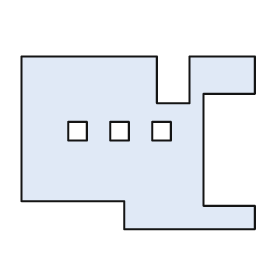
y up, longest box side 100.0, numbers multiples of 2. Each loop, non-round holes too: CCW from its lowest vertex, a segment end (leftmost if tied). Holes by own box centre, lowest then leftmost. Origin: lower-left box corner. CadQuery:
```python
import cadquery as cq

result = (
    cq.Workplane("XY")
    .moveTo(44.0, 0.0)
    .lineTo(100.0, 0.0)
    .lineTo(100.0, 10.0)
    .lineTo(78.0, 10.0)
    .lineTo(78.0, 58.0)
    .lineTo(100.0, 58.0)
    .lineTo(100.0, 74.0)
    .lineTo(72.0, 74.0)
    .lineTo(72.0, 54.0)
    .lineTo(58.0, 54.0)
    .lineTo(58.0, 74.0)
    .lineTo(0.0, 74.0)
    .lineTo(0.0, 12.0)
    .lineTo(44.0, 12.0)
    .close()
    .moveTo(20.0, 38.0)
    .lineTo(28.0, 38.0)
    .lineTo(28.0, 46.0)
    .lineTo(20.0, 46.0)
    .close()
    .moveTo(38.0, 38.0)
    .lineTo(46.0, 38.0)
    .lineTo(46.0, 46.0)
    .lineTo(38.0, 46.0)
    .close()
    .moveTo(56.0, 38.0)
    .lineTo(64.0, 38.0)
    .lineTo(64.0, 46.0)
    .lineTo(56.0, 46.0)
    .close()
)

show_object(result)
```